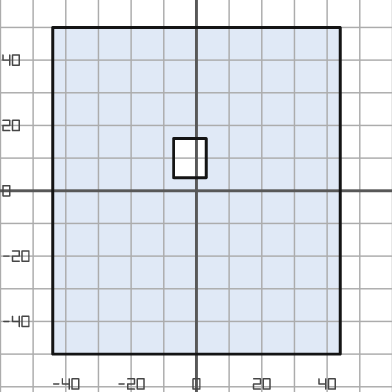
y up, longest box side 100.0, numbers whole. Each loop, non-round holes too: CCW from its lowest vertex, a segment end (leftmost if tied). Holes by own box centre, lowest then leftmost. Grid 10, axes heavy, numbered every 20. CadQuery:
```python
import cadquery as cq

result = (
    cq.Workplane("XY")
    .moveTo(-44.0, -50.0)
    .lineTo(44.0, -50.0)
    .lineTo(44.0, 50.0)
    .lineTo(-44.0, 50.0)
    .close()
    .moveTo(-7.0, 4.0)
    .lineTo(3.0, 4.0)
    .lineTo(3.0, 16.0)
    .lineTo(-7.0, 16.0)
    .close()
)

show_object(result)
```